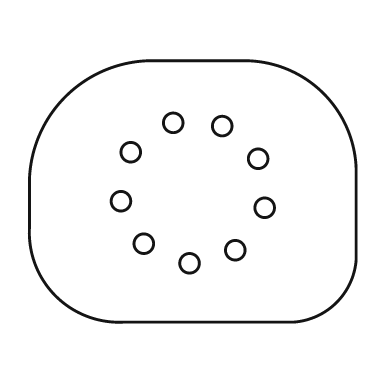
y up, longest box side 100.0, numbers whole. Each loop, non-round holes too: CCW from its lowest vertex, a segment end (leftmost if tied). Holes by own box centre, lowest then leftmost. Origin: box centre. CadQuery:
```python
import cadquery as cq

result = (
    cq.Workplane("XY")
    .moveTo(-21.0, -40.0)
    .lineTo(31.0, -40.0)
    .threePointArc((44.0, -34.0), (50.0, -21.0))
    .lineTo(50.0, 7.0)
    .threePointArc((40.0, 30.0), (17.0, 40.0))
    .lineTo(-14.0, 40.0)
    .threePointArc((-39.0, 29.0), (-50.0, 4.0))
    .lineTo(-50.0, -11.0)
    .threePointArc((-42.0, -32.0), (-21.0, -40.0))
    .close()
    .moveTo(-1.0, -22.0)
    .circle(3.0)
    .moveTo(13.0, -18.0)
    .circle(3.0)
    .moveTo(-15.0, -16.0)
    .circle(3.0)
    .moveTo(22.0, -5.0)
    .circle(3.0)
    .moveTo(-22.0, -3.0)
    .circle(3.0)
    .moveTo(20.0, 10.0)
    .circle(3.0)
    .moveTo(-19.0, 12.0)
    .circle(3.0)
    .moveTo(9.0, 20.0)
    .circle(3.0)
    .moveTo(-6.0, 21.0)
    .circle(3.0)
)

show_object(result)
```